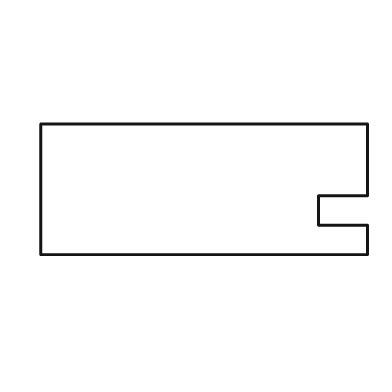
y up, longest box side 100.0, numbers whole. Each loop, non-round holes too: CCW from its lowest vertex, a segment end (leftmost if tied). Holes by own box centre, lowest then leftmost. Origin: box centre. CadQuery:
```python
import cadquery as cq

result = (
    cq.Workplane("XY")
    .moveTo(-50.0, -20.0)
    .lineTo(50.0, -20.0)
    .lineTo(50.0, -11.0)
    .lineTo(35.0, -11.0)
    .lineTo(35.0, -2.0)
    .lineTo(50.0, -2.0)
    .lineTo(50.0, 20.0)
    .lineTo(-50.0, 20.0)
    .close()
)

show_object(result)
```